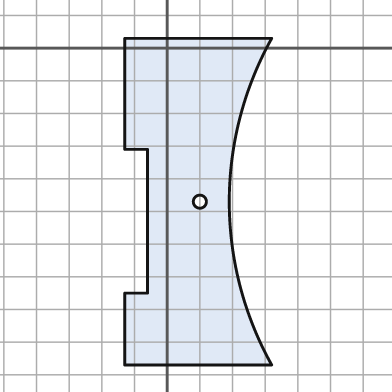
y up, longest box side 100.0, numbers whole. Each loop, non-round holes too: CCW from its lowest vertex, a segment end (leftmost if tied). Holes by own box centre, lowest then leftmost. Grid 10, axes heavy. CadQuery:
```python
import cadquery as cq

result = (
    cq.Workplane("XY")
    .moveTo(-13.0, -97.0)
    .lineTo(32.0, -97.0)
    .threePointArc((19.0, -47.0), (32.0, 3.0))
    .lineTo(-13.0, 3.0)
    .lineTo(-13.0, -31.0)
    .lineTo(-6.0, -31.0)
    .lineTo(-6.0, -75.0)
    .lineTo(-13.0, -75.0)
    .close()
    .moveTo(10.0, -47.0)
    .circle(2.0)
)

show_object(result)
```